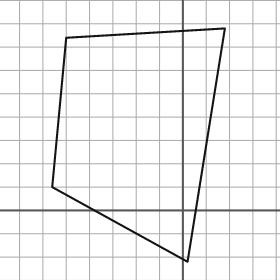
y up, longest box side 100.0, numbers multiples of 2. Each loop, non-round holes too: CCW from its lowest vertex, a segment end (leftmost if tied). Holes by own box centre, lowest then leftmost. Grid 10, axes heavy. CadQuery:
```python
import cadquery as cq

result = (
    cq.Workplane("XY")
    .moveTo(2.0, -22.0)
    .lineTo(18.0, 78.0)
    .lineTo(-50.0, 74.0)
    .lineTo(-56.0, 10.0)
    .close()
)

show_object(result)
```